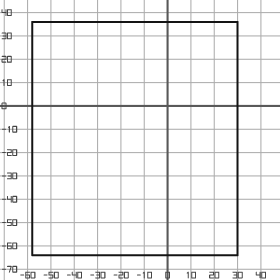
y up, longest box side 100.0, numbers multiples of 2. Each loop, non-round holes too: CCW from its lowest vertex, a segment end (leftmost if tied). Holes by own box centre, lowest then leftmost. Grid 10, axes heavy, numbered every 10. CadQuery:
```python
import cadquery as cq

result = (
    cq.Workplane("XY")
    .moveTo(-58.0, -64.0)
    .lineTo(30.0, -64.0)
    .lineTo(30.0, 36.0)
    .lineTo(-58.0, 36.0)
    .close()
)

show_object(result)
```